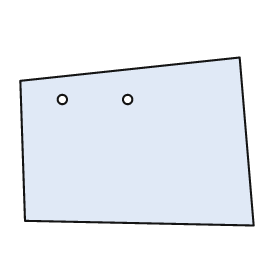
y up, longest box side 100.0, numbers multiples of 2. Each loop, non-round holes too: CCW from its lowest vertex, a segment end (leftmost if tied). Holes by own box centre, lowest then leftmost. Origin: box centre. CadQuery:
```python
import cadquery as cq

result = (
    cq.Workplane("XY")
    .moveTo(50.0, -36.0)
    .lineTo(44.0, 36.0)
    .lineTo(-50.0, 26.0)
    .lineTo(-48.0, -34.0)
    .close()
    .moveTo(-32.0, 18.0)
    .circle(2.0)
    .moveTo(-4.0, 18.0)
    .circle(2.0)
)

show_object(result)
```